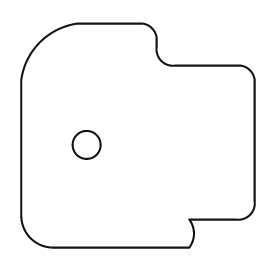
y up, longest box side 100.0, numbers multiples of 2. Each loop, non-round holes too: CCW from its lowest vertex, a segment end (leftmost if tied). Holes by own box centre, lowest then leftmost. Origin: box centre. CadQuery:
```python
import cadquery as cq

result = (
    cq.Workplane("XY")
    .moveTo(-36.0, -48.0)
    .lineTo(22.0, -48.0)
    .threePointArc((24.0, -42.0), (22.0, -36.0))
    .lineTo(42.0, -36.0)
    .threePointArc((48.0, -34.0), (50.0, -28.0))
    .lineTo(50.0, 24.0)
    .threePointArc((48.0, 28.0), (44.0, 30.0))
    .lineTo(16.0, 30.0)
    .threePointArc((10.0, 32.0), (8.0, 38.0))
    .lineTo(8.0, 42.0)
    .threePointArc((6.0, 46.0), (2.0, 48.0))
    .lineTo(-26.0, 48.0)
    .threePointArc((-42.0, 40.0), (-50.0, 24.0))
    .lineTo(-50.0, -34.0)
    .threePointArc((-46.0, -44.0), (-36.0, -48.0))
    .close()
    .moveTo(-22.0, -4.0)
    .circle(6.0)
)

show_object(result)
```